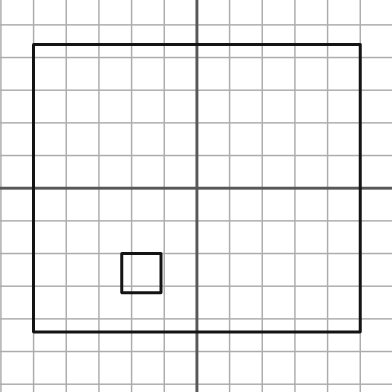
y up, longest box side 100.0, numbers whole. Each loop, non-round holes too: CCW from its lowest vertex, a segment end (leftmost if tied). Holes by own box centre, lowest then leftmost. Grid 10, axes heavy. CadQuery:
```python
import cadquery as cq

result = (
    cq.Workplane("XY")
    .moveTo(-50.0, -44.0)
    .lineTo(50.0, -44.0)
    .lineTo(50.0, 44.0)
    .lineTo(-50.0, 44.0)
    .close()
    .moveTo(-23.0, -32.0)
    .lineTo(-11.0, -32.0)
    .lineTo(-11.0, -20.0)
    .lineTo(-23.0, -20.0)
    .close()
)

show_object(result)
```